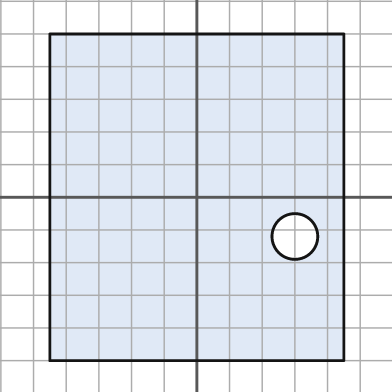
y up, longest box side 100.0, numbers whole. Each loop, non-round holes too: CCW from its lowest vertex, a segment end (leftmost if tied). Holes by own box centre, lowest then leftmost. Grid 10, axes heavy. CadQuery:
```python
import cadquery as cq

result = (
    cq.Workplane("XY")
    .moveTo(-45.0, -50.0)
    .lineTo(45.0, -50.0)
    .lineTo(45.0, 50.0)
    .lineTo(-45.0, 50.0)
    .close()
    .moveTo(30.0, -12.0)
    .circle(7.0)
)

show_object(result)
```